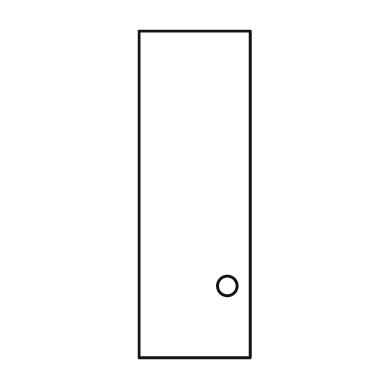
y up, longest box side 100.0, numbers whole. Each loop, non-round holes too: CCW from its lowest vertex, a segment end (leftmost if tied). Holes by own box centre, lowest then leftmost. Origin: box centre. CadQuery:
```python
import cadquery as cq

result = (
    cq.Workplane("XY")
    .moveTo(-17.0, -50.0)
    .lineTo(17.0, -50.0)
    .lineTo(17.0, 50.0)
    .lineTo(-17.0, 50.0)
    .close()
    .moveTo(10.0, -28.0)
    .circle(3.0)
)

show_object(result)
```